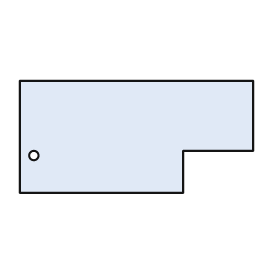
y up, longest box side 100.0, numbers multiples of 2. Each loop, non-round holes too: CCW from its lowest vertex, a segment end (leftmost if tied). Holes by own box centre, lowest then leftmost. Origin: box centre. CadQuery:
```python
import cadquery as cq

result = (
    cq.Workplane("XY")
    .moveTo(-50.0, -24.0)
    .lineTo(20.0, -24.0)
    .lineTo(20.0, -6.0)
    .lineTo(50.0, -6.0)
    .lineTo(50.0, 24.0)
    .lineTo(-50.0, 24.0)
    .close()
    .moveTo(-44.0, -8.0)
    .circle(2.0)
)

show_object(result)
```